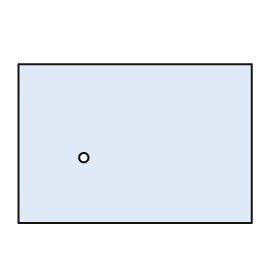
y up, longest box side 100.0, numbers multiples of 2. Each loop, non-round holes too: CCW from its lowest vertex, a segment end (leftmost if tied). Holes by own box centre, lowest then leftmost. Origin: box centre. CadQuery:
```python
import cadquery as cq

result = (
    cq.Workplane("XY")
    .moveTo(-50.0, -34.0)
    .lineTo(50.0, -34.0)
    .lineTo(50.0, 34.0)
    .lineTo(-50.0, 34.0)
    .close()
    .moveTo(-22.0, -6.0)
    .circle(2.0)
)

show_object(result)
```